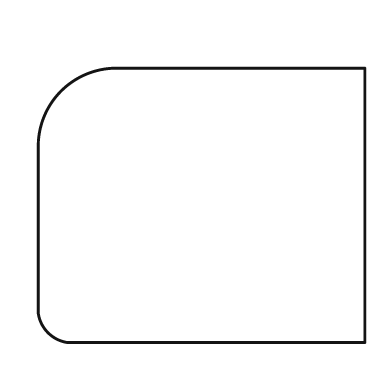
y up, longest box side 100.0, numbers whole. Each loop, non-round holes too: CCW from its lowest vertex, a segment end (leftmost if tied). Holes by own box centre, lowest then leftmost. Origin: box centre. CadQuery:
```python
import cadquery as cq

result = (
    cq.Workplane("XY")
    .moveTo(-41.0, -42.0)
    .lineTo(50.0, -42.0)
    .lineTo(50.0, 42.0)
    .lineTo(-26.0, 42.0)
    .threePointArc((-43.0, 35.0), (-50.0, 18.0))
    .lineTo(-50.0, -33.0)
    .threePointArc((-47.0, -39.0), (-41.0, -42.0))
    .close()
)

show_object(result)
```